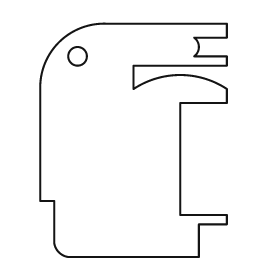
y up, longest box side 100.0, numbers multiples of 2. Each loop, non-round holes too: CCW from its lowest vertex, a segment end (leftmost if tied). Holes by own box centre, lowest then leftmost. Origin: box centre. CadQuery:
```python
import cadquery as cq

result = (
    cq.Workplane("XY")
    .moveTo(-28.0, -50.0)
    .lineTo(28.0, -50.0)
    .lineTo(28.0, -36.0)
    .lineTo(40.0, -36.0)
    .lineTo(40.0, -32.0)
    .lineTo(20.0, -32.0)
    .lineTo(20.0, 16.0)
    .lineTo(40.0, 16.0)
    .lineTo(40.0, 22.0)
    .threePointArc((20.0, 28.0), (0.0, 22.0))
    .lineTo(0.0, 32.0)
    .lineTo(40.0, 32.0)
    .lineTo(40.0, 36.0)
    .lineTo(26.0, 36.0)
    .threePointArc((28.0, 40.0), (26.0, 44.0))
    .lineTo(40.0, 44.0)
    .lineTo(40.0, 50.0)
    .lineTo(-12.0, 50.0)
    .threePointArc((-32.0, 42.0), (-40.0, 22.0))
    .lineTo(-40.0, -26.0)
    .lineTo(-34.0, -26.0)
    .lineTo(-34.0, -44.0)
    .threePointArc((-32.0, -48.0), (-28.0, -50.0))
    .close()
    .moveTo(-24.0, 36.0)
    .circle(4.0)
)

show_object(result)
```